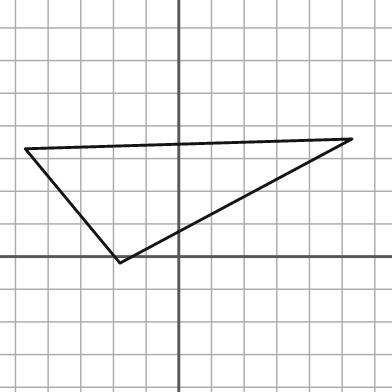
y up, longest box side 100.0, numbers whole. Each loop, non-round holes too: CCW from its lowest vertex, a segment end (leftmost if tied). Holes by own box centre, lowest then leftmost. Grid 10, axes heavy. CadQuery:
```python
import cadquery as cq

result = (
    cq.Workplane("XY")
    .moveTo(-18.0, -2.0)
    .lineTo(53.0, 36.0)
    .lineTo(-47.0, 33.0)
    .close()
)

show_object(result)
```